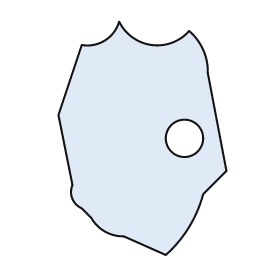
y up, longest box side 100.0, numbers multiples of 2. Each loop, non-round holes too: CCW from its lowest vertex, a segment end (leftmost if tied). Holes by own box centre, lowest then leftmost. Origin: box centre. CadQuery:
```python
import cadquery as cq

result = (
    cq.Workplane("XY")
    .moveTo(10.0, -50.0)
    .threePointArc((20.0, -38.0), (26.0, -24.0))
    .lineTo(36.0, -14.0)
    .lineTo(28.0, 28.0)
    .threePointArc((26.0, 38.0), (20.0, 46.0))
    .threePointArc((4.0, 40.0), (-10.0, 50.0))
    .threePointArc((-16.0, 42.0), (-26.0, 40.0))
    .lineTo(-36.0, 10.0)
    .lineTo(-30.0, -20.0)
    .threePointArc((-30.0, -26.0), (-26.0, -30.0))
    .lineTo(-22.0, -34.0)
    .threePointArc((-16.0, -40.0), (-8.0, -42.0))
    .close()
    .moveTo(18.0, 0.0)
    .circle(8.0)
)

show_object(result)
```